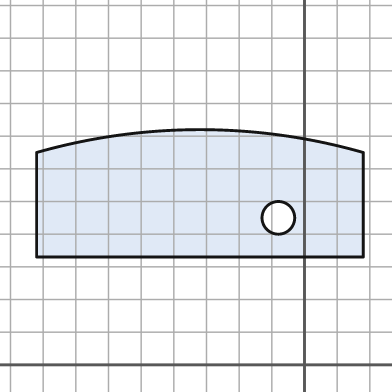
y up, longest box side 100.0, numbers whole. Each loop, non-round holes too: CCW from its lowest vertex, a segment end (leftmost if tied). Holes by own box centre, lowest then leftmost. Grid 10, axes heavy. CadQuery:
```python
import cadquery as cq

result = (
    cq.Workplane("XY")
    .moveTo(-82.0, 33.0)
    .lineTo(18.0, 33.0)
    .lineTo(18.0, 65.0)
    .threePointArc((-32.0, 72.0), (-82.0, 65.0))
    .close()
    .moveTo(-8.0, 45.0)
    .circle(5.0)
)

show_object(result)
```